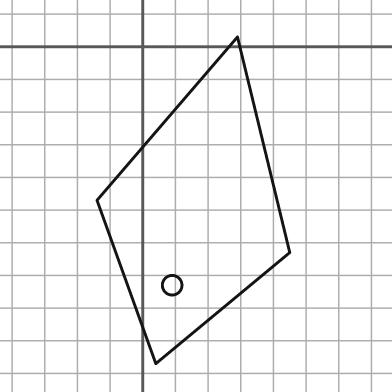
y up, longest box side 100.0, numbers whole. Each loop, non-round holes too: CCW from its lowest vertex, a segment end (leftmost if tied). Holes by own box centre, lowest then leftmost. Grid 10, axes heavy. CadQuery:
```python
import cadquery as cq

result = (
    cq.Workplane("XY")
    .moveTo(4.0, -97.0)
    .lineTo(45.0, -63.0)
    .lineTo(29.0, 3.0)
    .lineTo(-14.0, -47.0)
    .close()
    .moveTo(9.0, -73.0)
    .circle(3.0)
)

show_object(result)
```